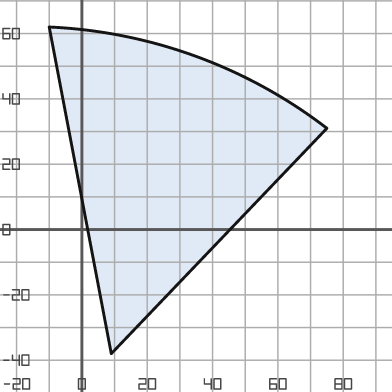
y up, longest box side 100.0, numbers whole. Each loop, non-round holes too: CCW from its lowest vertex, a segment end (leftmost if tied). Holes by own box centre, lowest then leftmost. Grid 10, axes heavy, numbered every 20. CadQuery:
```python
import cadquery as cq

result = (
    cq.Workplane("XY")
    .moveTo(9.0, -38.0)
    .lineTo(75.0, 31.0)
    .threePointArc((35.0, 53.0), (-10.0, 62.0))
    .close()
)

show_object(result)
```